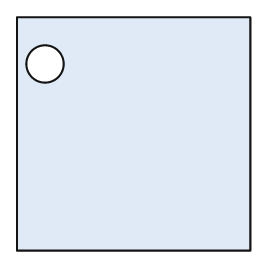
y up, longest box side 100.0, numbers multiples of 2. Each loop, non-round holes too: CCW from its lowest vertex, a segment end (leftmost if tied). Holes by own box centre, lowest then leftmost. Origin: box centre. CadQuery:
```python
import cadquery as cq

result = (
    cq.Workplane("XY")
    .moveTo(-50.0, -50.0)
    .lineTo(50.0, -50.0)
    .lineTo(50.0, 50.0)
    .lineTo(-50.0, 50.0)
    .close()
    .moveTo(-38.0, 30.0)
    .circle(8.0)
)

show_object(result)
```